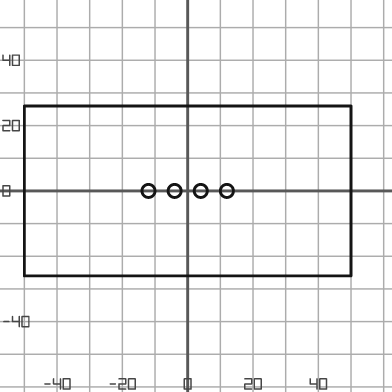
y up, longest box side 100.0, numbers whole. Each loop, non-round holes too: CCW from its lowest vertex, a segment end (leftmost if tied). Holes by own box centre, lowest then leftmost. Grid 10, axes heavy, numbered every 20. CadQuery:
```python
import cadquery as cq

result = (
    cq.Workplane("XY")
    .moveTo(-50.0, -26.0)
    .lineTo(50.0, -26.0)
    .lineTo(50.0, 26.0)
    .lineTo(-50.0, 26.0)
    .close()
    .moveTo(-12.0, 0.0)
    .circle(2.0)
    .moveTo(-4.0, 0.0)
    .circle(2.0)
    .moveTo(4.0, 0.0)
    .circle(2.0)
    .moveTo(12.0, 0.0)
    .circle(2.0)
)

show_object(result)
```